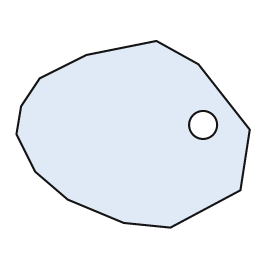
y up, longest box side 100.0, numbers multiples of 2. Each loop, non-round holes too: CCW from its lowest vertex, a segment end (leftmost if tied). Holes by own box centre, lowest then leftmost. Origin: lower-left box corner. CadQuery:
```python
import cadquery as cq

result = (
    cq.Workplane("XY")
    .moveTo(66.0, 0.0)
    .lineTo(96.0, 16.0)
    .lineTo(100.0, 42.0)
    .lineTo(78.0, 70.0)
    .lineTo(60.0, 80.0)
    .lineTo(30.0, 74.0)
    .lineTo(10.0, 64.0)
    .lineTo(2.0, 52.0)
    .lineTo(0.0, 40.0)
    .lineTo(8.0, 24.0)
    .lineTo(22.0, 12.0)
    .lineTo(46.0, 2.0)
    .close()
    .moveTo(80.0, 44.0)
    .circle(6.0)
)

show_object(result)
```